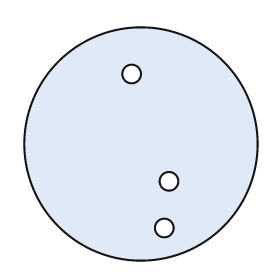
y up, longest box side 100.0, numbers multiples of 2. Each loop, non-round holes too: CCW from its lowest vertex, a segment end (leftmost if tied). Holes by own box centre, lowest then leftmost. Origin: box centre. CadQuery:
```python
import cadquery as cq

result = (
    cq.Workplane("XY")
    .moveTo(0.0, 0.0)
    .circle(50.0)
    .moveTo(10.0, -36.0)
    .circle(4.0)
    .moveTo(12.0, -16.0)
    .circle(4.0)
    .moveTo(-4.0, 30.0)
    .circle(4.0)
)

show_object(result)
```